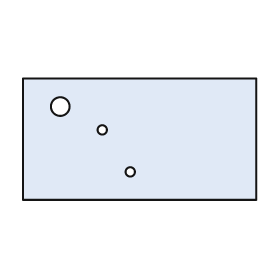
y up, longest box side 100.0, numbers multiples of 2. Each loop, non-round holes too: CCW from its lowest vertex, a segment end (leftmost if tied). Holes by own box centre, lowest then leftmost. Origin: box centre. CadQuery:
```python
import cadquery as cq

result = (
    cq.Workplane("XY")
    .moveTo(-50.0, -26.0)
    .lineTo(50.0, -26.0)
    .lineTo(50.0, 26.0)
    .lineTo(-50.0, 26.0)
    .close()
    .moveTo(-4.0, -14.0)
    .circle(2.0)
    .moveTo(-16.0, 4.0)
    .circle(2.0)
    .moveTo(-34.0, 14.0)
    .circle(4.0)
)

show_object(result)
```